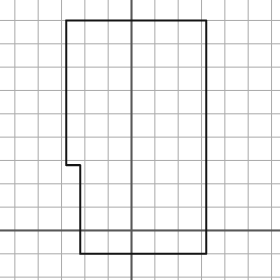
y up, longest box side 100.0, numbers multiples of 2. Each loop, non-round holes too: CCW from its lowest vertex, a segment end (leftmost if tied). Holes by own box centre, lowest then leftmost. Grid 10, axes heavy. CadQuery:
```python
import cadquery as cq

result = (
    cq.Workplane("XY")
    .moveTo(-22.0, -10.0)
    .lineTo(32.0, -10.0)
    .lineTo(32.0, 90.0)
    .lineTo(-28.0, 90.0)
    .lineTo(-28.0, 28.0)
    .lineTo(-22.0, 28.0)
    .close()
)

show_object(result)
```